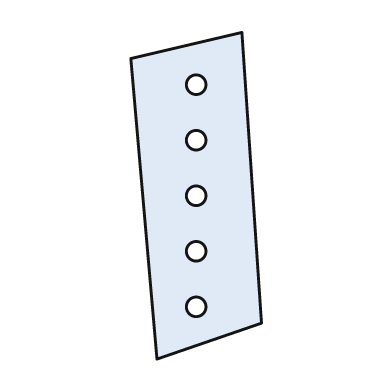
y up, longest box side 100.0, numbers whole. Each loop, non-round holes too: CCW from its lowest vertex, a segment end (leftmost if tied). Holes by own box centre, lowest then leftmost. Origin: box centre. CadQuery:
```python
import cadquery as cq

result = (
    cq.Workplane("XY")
    .moveTo(-12.0, -50.0)
    .lineTo(20.0, -39.0)
    .lineTo(14.0, 50.0)
    .lineTo(-20.0, 42.0)
    .close()
    .moveTo(0.0, -34.0)
    .circle(3.0)
    .moveTo(0.0, -17.0)
    .circle(3.0)
    .moveTo(0.0, 0.0)
    .circle(3.0)
    .moveTo(0.0, 17.0)
    .circle(3.0)
    .moveTo(0.0, 34.0)
    .circle(3.0)
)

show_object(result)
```